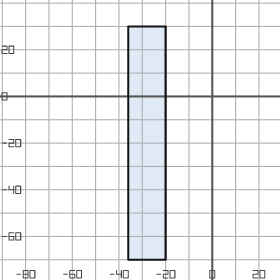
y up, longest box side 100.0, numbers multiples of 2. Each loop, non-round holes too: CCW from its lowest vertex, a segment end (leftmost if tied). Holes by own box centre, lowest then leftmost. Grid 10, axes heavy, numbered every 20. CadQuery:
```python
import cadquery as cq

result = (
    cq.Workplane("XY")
    .moveTo(-36.0, -70.0)
    .lineTo(-20.0, -70.0)
    .lineTo(-20.0, 30.0)
    .lineTo(-36.0, 30.0)
    .close()
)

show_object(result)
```